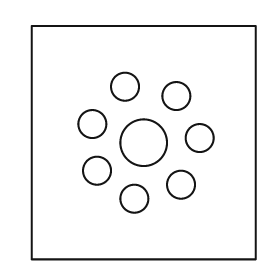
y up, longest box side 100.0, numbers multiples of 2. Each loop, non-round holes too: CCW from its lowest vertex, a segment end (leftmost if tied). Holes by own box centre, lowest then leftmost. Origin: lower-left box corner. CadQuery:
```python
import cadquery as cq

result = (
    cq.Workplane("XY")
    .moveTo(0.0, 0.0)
    .lineTo(96.0, 0.0)
    .lineTo(96.0, 100.0)
    .lineTo(0.0, 100.0)
    .close()
    .moveTo(44.0, 26.0)
    .circle(6.0)
    .moveTo(64.0, 32.0)
    .circle(6.0)
    .moveTo(28.0, 38.0)
    .circle(6.0)
    .moveTo(48.0, 50.0)
    .circle(10.0)
    .moveTo(72.0, 52.0)
    .circle(6.0)
    .moveTo(26.0, 58.0)
    .circle(6.0)
    .moveTo(62.0, 70.0)
    .circle(6.0)
    .moveTo(40.0, 74.0)
    .circle(6.0)
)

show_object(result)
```